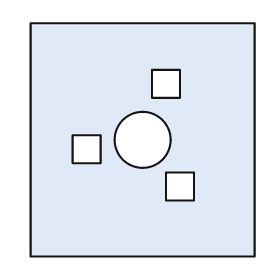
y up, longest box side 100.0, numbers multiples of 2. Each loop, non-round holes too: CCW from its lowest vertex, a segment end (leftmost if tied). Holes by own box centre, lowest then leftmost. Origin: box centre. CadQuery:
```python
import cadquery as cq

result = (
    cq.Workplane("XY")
    .moveTo(-48.0, -50.0)
    .lineTo(48.0, -50.0)
    .lineTo(48.0, 50.0)
    .lineTo(-48.0, 50.0)
    .close()
    .moveTo(10.0, -26.0)
    .lineTo(22.0, -26.0)
    .lineTo(22.0, -14.0)
    .lineTo(10.0, -14.0)
    .close()
    .moveTo(-30.0, -10.0)
    .lineTo(-18.0, -10.0)
    .lineTo(-18.0, 2.0)
    .lineTo(-30.0, 2.0)
    .close()
    .moveTo(0.0, 0.0)
    .circle(12.0)
    .moveTo(4.0, 18.0)
    .lineTo(16.0, 18.0)
    .lineTo(16.0, 30.0)
    .lineTo(4.0, 30.0)
    .close()
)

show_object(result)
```